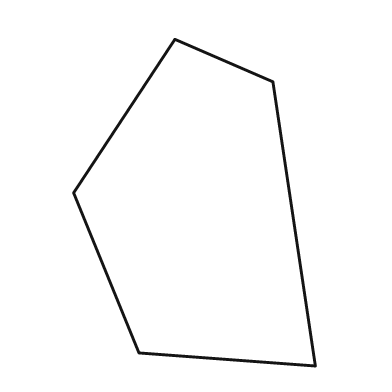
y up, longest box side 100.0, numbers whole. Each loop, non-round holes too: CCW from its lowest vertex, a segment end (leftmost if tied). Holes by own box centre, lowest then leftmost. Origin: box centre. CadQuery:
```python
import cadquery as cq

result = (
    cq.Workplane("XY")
    .moveTo(37.0, -50.0)
    .lineTo(24.0, 37.0)
    .lineTo(-6.0, 50.0)
    .lineTo(-37.0, 3.0)
    .lineTo(-17.0, -46.0)
    .close()
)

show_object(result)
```